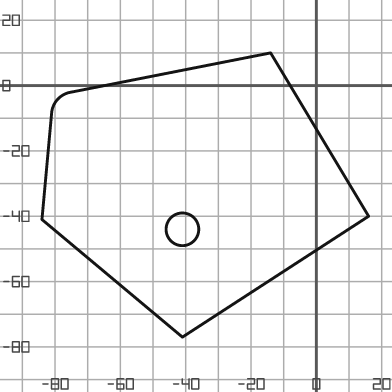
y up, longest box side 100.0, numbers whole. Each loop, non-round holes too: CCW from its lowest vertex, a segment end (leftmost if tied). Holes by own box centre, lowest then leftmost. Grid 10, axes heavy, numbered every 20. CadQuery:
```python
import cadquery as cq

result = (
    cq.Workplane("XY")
    .moveTo(-41.0, -77.0)
    .lineTo(16.0, -40.0)
    .lineTo(-14.0, 10.0)
    .lineTo(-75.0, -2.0)
    .threePointArc((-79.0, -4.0), (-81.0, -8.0))
    .lineTo(-84.0, -41.0)
    .close()
    .moveTo(-41.0, -44.0)
    .circle(5.0)
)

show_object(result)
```